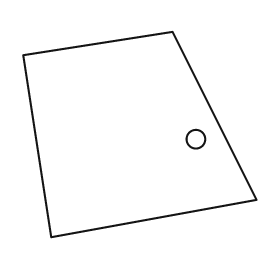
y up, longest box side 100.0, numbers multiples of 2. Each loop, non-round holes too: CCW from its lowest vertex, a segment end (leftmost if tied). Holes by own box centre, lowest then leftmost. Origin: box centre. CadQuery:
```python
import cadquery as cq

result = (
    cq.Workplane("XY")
    .moveTo(-38.0, -44.0)
    .lineTo(50.0, -28.0)
    .lineTo(14.0, 44.0)
    .lineTo(-50.0, 34.0)
    .close()
    .moveTo(24.0, -2.0)
    .circle(4.0)
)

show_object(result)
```